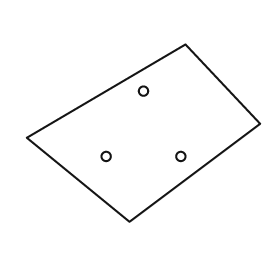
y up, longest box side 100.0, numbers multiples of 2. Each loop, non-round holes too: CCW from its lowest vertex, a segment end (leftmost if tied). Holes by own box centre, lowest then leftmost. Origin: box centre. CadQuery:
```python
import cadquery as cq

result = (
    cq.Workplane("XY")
    .moveTo(-6.0, -38.0)
    .lineTo(50.0, 4.0)
    .lineTo(18.0, 38.0)
    .lineTo(-50.0, -2.0)
    .close()
    .moveTo(-16.0, -10.0)
    .circle(2.0)
    .moveTo(16.0, -10.0)
    .circle(2.0)
    .moveTo(0.0, 18.0)
    .circle(2.0)
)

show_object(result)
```